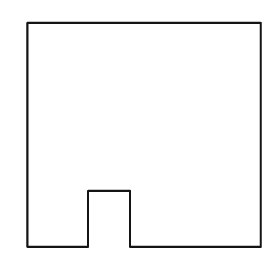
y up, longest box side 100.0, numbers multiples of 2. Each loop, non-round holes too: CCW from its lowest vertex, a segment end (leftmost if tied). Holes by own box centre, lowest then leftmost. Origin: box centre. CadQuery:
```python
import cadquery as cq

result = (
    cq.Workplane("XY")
    .moveTo(-50.0, -48.0)
    .lineTo(-24.0, -48.0)
    .lineTo(-24.0, -24.0)
    .lineTo(-6.0, -24.0)
    .lineTo(-6.0, -48.0)
    .lineTo(50.0, -48.0)
    .lineTo(50.0, 48.0)
    .lineTo(-50.0, 48.0)
    .close()
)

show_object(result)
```